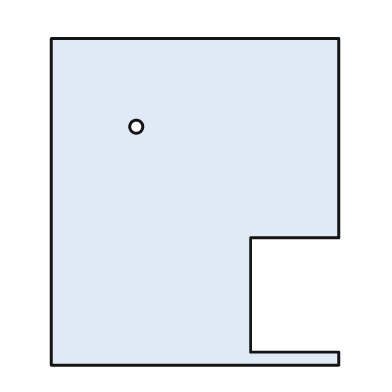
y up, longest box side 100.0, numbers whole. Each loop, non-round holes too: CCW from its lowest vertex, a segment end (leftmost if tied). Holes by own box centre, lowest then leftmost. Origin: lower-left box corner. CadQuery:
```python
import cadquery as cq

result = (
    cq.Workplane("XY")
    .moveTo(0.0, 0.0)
    .lineTo(88.0, 0.0)
    .lineTo(88.0, 4.0)
    .lineTo(61.0, 4.0)
    .lineTo(61.0, 39.0)
    .lineTo(88.0, 39.0)
    .lineTo(88.0, 100.0)
    .lineTo(0.0, 100.0)
    .close()
    .moveTo(26.0, 73.0)
    .circle(2.0)
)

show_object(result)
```